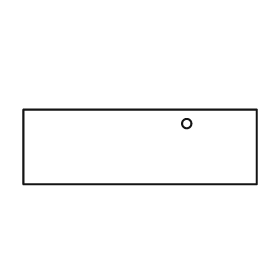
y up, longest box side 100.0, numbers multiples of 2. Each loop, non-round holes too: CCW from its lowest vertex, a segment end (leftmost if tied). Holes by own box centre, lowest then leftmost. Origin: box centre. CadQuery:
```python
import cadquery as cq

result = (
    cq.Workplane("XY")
    .moveTo(-50.0, -16.0)
    .lineTo(50.0, -16.0)
    .lineTo(50.0, 16.0)
    .lineTo(-50.0, 16.0)
    .close()
    .moveTo(20.0, 10.0)
    .circle(2.0)
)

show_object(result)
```